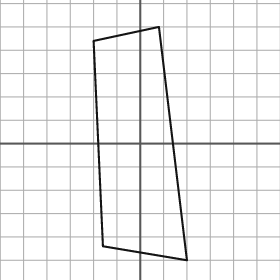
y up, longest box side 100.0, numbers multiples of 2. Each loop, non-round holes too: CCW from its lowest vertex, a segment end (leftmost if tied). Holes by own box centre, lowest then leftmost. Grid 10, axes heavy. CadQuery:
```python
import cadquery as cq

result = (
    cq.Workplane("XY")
    .moveTo(20.0, -50.0)
    .lineTo(8.0, 50.0)
    .lineTo(-20.0, 44.0)
    .lineTo(-16.0, -44.0)
    .close()
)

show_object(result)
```